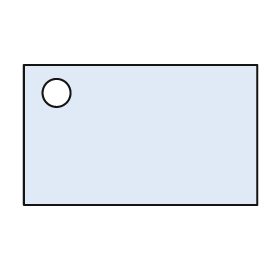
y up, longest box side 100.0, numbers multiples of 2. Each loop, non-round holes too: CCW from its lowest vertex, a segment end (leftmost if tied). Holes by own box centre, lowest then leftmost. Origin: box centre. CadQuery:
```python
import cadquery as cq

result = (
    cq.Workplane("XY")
    .moveTo(-50.0, -30.0)
    .lineTo(50.0, -30.0)
    .lineTo(50.0, 30.0)
    .lineTo(-50.0, 30.0)
    .close()
    .moveTo(-36.0, 18.0)
    .circle(6.0)
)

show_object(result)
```